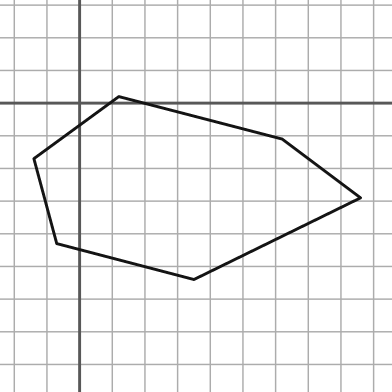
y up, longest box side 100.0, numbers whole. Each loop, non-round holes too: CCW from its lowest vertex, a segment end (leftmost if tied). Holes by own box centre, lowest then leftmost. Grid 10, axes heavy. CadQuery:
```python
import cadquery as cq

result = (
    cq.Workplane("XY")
    .moveTo(35.0, -54.0)
    .lineTo(86.0, -29.0)
    .lineTo(62.0, -11.0)
    .lineTo(12.0, 2.0)
    .lineTo(-14.0, -17.0)
    .lineTo(-7.0, -43.0)
    .close()
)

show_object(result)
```